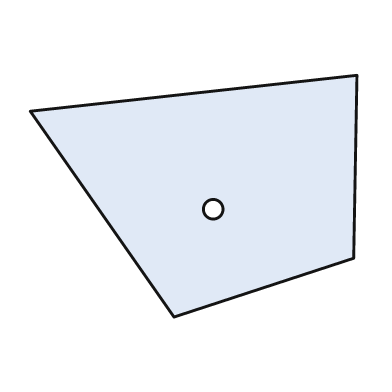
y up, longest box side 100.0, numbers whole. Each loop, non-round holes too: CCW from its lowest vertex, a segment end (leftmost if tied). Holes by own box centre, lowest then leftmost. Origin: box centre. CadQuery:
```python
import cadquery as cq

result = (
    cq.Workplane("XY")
    .moveTo(-6.0, -37.0)
    .lineTo(49.0, -19.0)
    .lineTo(50.0, 37.0)
    .lineTo(-50.0, 26.0)
    .close()
    .moveTo(6.0, -4.0)
    .circle(3.0)
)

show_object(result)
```